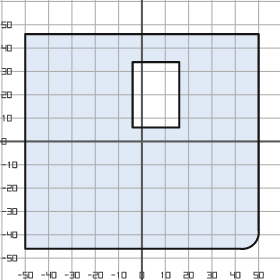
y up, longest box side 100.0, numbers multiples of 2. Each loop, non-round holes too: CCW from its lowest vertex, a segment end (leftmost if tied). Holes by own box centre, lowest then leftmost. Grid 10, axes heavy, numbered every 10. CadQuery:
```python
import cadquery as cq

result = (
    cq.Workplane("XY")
    .moveTo(-50.0, -46.0)
    .lineTo(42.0, -46.0)
    .threePointArc((48.0, -44.0), (50.0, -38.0))
    .lineTo(50.0, 46.0)
    .lineTo(-50.0, 46.0)
    .close()
    .moveTo(-4.0, 6.0)
    .lineTo(16.0, 6.0)
    .lineTo(16.0, 34.0)
    .lineTo(-4.0, 34.0)
    .close()
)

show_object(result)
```